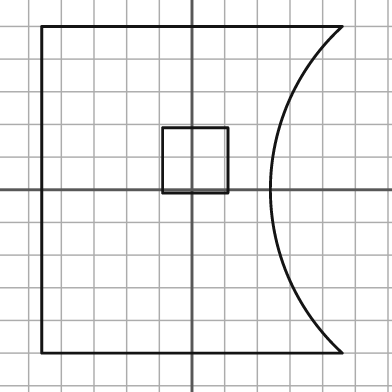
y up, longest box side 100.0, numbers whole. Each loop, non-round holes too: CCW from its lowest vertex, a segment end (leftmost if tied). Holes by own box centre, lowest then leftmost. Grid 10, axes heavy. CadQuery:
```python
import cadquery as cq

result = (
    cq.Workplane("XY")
    .moveTo(-46.0, -50.0)
    .lineTo(46.0, -50.0)
    .threePointArc((24.0, 0.0), (46.0, 50.0))
    .lineTo(-46.0, 50.0)
    .close()
    .moveTo(-9.0, -1.0)
    .lineTo(11.0, -1.0)
    .lineTo(11.0, 19.0)
    .lineTo(-9.0, 19.0)
    .close()
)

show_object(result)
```